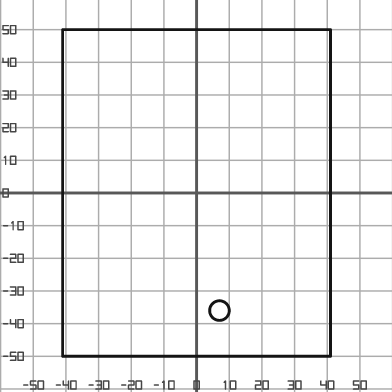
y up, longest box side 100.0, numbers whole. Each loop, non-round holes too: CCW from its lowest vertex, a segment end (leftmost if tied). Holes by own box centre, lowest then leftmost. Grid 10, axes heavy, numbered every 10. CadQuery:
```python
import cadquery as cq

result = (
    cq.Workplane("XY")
    .moveTo(-41.0, -50.0)
    .lineTo(41.0, -50.0)
    .lineTo(41.0, 50.0)
    .lineTo(-41.0, 50.0)
    .close()
    .moveTo(7.0, -36.0)
    .circle(3.0)
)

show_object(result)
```